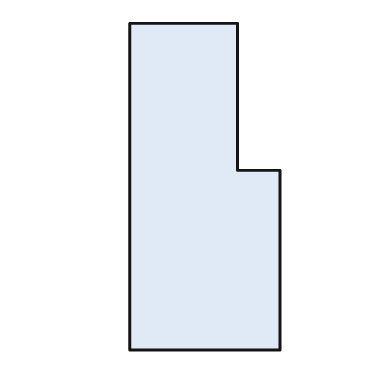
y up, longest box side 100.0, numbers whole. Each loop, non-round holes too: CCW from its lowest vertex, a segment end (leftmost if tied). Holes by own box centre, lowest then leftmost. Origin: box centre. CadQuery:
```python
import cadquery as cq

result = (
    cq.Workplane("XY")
    .moveTo(-23.0, -50.0)
    .lineTo(23.0, -50.0)
    .lineTo(23.0, 5.0)
    .lineTo(10.0, 5.0)
    .lineTo(10.0, 50.0)
    .lineTo(-23.0, 50.0)
    .close()
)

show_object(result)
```